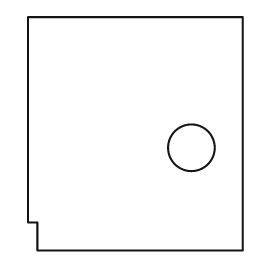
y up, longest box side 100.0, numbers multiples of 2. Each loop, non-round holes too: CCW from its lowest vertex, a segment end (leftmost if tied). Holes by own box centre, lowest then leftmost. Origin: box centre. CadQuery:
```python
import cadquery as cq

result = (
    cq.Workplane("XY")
    .moveTo(-42.0, -50.0)
    .lineTo(46.0, -50.0)
    .lineTo(46.0, 50.0)
    .lineTo(-46.0, 50.0)
    .lineTo(-46.0, -38.0)
    .lineTo(-42.0, -38.0)
    .close()
    .moveTo(24.0, -6.0)
    .circle(10.0)
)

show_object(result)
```